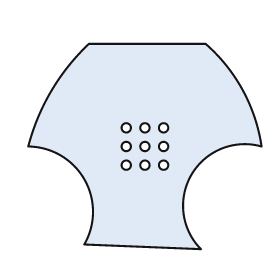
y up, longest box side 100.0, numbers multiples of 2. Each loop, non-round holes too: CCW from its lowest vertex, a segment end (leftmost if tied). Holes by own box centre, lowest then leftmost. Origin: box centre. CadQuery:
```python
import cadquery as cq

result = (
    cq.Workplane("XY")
    .moveTo(24.0, -44.0)
    .threePointArc((20.0, -12.0), (50.0, 0.0))
    .threePointArc((42.0, 24.0), (26.0, 44.0))
    .lineTo(-24.0, 44.0)
    .threePointArc((-40.0, 24.0), (-50.0, 0.0))
    .threePointArc((-26.0, -14.0), (-26.0, -42.0))
    .close()
    .moveTo(-8.0, -8.0)
    .circle(2.0)
    .moveTo(0.0, -8.0)
    .circle(2.0)
    .moveTo(8.0, -8.0)
    .circle(2.0)
    .moveTo(-8.0, 0.0)
    .circle(2.0)
    .moveTo(0.0, 0.0)
    .circle(2.0)
    .moveTo(8.0, 0.0)
    .circle(2.0)
    .moveTo(-8.0, 8.0)
    .circle(2.0)
    .moveTo(0.0, 8.0)
    .circle(2.0)
    .moveTo(8.0, 8.0)
    .circle(2.0)
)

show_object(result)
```